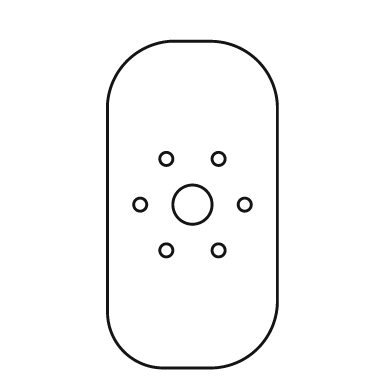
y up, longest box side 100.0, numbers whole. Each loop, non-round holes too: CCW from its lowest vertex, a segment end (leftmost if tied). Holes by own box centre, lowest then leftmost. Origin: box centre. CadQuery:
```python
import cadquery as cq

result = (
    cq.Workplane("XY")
    .moveTo(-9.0, -50.0)
    .lineTo(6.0, -50.0)
    .threePointArc((20.0, -44.0), (26.0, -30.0))
    .lineTo(26.0, 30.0)
    .threePointArc((20.0, 44.0), (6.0, 50.0))
    .lineTo(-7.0, 50.0)
    .threePointArc((-20.0, 44.0), (-26.0, 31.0))
    .lineTo(-26.0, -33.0)
    .threePointArc((-21.0, -45.0), (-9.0, -50.0))
    .close()
    .moveTo(-8.0, -14.0)
    .circle(2.0)
    .moveTo(8.0, -14.0)
    .circle(2.0)
    .moveTo(-16.0, 0.0)
    .circle(2.0)
    .moveTo(0.0, 0.0)
    .circle(6.0)
    .moveTo(16.0, 0.0)
    .circle(2.0)
    .moveTo(-8.0, 14.0)
    .circle(2.0)
    .moveTo(8.0, 14.0)
    .circle(2.0)
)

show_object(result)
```